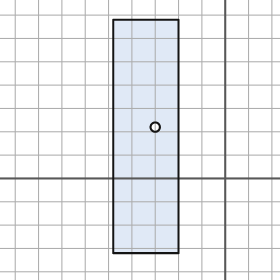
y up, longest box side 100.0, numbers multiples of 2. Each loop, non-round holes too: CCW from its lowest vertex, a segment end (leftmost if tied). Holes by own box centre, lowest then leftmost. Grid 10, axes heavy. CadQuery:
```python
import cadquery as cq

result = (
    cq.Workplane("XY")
    .moveTo(-48.0, -32.0)
    .lineTo(-20.0, -32.0)
    .lineTo(-20.0, 68.0)
    .lineTo(-48.0, 68.0)
    .close()
    .moveTo(-30.0, 22.0)
    .circle(2.0)
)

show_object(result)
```